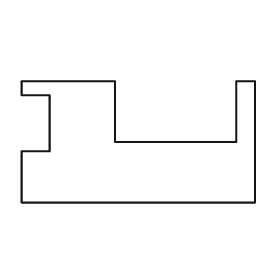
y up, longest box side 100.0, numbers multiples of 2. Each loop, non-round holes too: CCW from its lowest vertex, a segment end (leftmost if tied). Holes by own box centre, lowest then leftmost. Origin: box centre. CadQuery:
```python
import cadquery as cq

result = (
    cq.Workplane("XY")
    .moveTo(-50.0, -26.0)
    .lineTo(50.0, -26.0)
    .lineTo(50.0, 26.0)
    .lineTo(42.0, 26.0)
    .lineTo(42.0, 0.0)
    .lineTo(-10.0, 0.0)
    .lineTo(-10.0, 26.0)
    .lineTo(-50.0, 26.0)
    .lineTo(-50.0, 20.0)
    .lineTo(-38.0, 20.0)
    .lineTo(-38.0, -4.0)
    .lineTo(-50.0, -4.0)
    .close()
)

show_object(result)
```